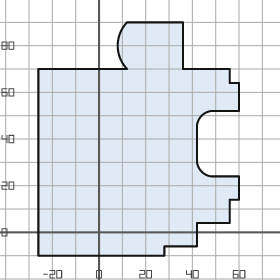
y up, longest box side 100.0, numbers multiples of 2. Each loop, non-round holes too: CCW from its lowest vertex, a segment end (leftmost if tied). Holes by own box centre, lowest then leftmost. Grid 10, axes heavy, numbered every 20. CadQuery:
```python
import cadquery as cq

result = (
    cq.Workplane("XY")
    .moveTo(-26.0, -10.0)
    .lineTo(28.0, -10.0)
    .lineTo(28.0, -6.0)
    .lineTo(42.0, -6.0)
    .lineTo(42.0, 4.0)
    .lineTo(56.0, 4.0)
    .lineTo(56.0, 14.0)
    .lineTo(60.0, 14.0)
    .lineTo(60.0, 24.0)
    .lineTo(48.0, 24.0)
    .threePointArc((44.0, 26.0), (42.0, 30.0))
    .lineTo(42.0, 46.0)
    .threePointArc((44.0, 50.0), (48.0, 52.0))
    .lineTo(60.0, 52.0)
    .lineTo(60.0, 64.0)
    .lineTo(56.0, 64.0)
    .lineTo(56.0, 70.0)
    .lineTo(36.0, 70.0)
    .lineTo(36.0, 90.0)
    .lineTo(12.0, 90.0)
    .threePointArc((8.0, 80.0), (12.0, 70.0))
    .lineTo(-26.0, 70.0)
    .close()
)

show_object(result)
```